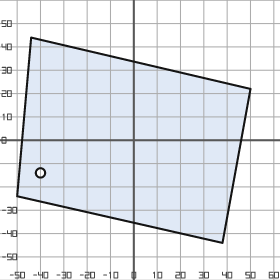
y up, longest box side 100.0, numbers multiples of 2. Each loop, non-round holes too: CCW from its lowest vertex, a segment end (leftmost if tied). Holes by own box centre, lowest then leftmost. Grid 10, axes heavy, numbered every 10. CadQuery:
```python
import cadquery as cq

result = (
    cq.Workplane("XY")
    .moveTo(38.0, -44.0)
    .lineTo(50.0, 22.0)
    .lineTo(-44.0, 44.0)
    .lineTo(-50.0, -24.0)
    .close()
    .moveTo(-40.0, -14.0)
    .circle(2.0)
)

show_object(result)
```